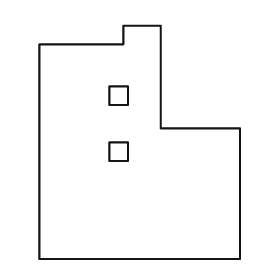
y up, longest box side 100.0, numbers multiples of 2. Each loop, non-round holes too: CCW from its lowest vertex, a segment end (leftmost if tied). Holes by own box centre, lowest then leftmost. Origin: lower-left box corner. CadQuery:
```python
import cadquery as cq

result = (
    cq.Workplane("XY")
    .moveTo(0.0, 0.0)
    .lineTo(86.0, 0.0)
    .lineTo(86.0, 56.0)
    .lineTo(52.0, 56.0)
    .lineTo(52.0, 100.0)
    .lineTo(36.0, 100.0)
    .lineTo(36.0, 92.0)
    .lineTo(0.0, 92.0)
    .close()
    .moveTo(30.0, 42.0)
    .lineTo(38.0, 42.0)
    .lineTo(38.0, 50.0)
    .lineTo(30.0, 50.0)
    .close()
    .moveTo(30.0, 66.0)
    .lineTo(38.0, 66.0)
    .lineTo(38.0, 74.0)
    .lineTo(30.0, 74.0)
    .close()
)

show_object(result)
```